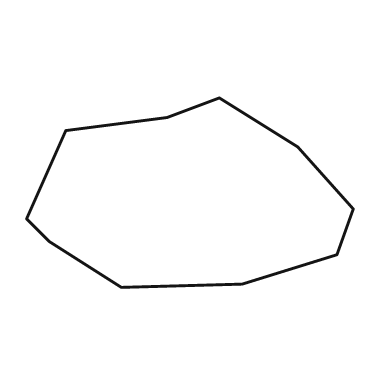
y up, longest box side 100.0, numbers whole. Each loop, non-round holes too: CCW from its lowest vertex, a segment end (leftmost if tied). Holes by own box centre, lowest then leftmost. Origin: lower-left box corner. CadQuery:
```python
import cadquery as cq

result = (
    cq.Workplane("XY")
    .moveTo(29.0, 0.0)
    .lineTo(66.0, 1.0)
    .lineTo(95.0, 10.0)
    .lineTo(100.0, 24.0)
    .lineTo(83.0, 43.0)
    .lineTo(59.0, 58.0)
    .lineTo(43.0, 52.0)
    .lineTo(12.0, 48.0)
    .lineTo(0.0, 21.0)
    .lineTo(7.0, 14.0)
    .close()
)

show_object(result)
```